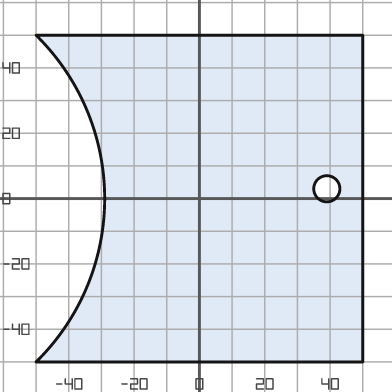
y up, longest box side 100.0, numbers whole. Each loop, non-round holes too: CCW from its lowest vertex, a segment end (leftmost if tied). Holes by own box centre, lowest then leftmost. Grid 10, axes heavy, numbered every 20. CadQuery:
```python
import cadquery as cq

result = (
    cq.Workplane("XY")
    .moveTo(-50.0, -50.0)
    .lineTo(50.0, -50.0)
    .lineTo(50.0, 50.0)
    .lineTo(-50.0, 50.0)
    .threePointArc((-29.0, 0.0), (-50.0, -50.0))
    .close()
    .moveTo(39.0, 3.0)
    .circle(4.0)
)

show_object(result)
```